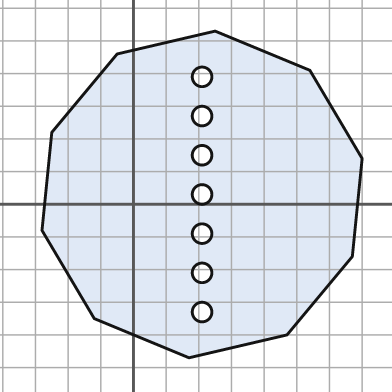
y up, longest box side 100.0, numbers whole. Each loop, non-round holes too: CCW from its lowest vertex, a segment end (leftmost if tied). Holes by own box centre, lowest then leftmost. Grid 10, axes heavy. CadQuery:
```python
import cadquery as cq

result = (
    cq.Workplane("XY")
    .moveTo(17.0, -47.0)
    .lineTo(47.0, -40.0)
    .lineTo(67.0, -16.0)
    .lineTo(70.0, 14.0)
    .lineTo(54.0, 41.0)
    .lineTo(25.0, 53.0)
    .lineTo(-5.0, 46.0)
    .lineTo(-25.0, 22.0)
    .lineTo(-28.0, -8.0)
    .lineTo(-12.0, -35.0)
    .close()
    .moveTo(21.0, -33.0)
    .circle(3.0)
    .moveTo(21.0, -21.0)
    .circle(3.0)
    .moveTo(21.0, -9.0)
    .circle(3.0)
    .moveTo(21.0, 3.0)
    .circle(3.0)
    .moveTo(21.0, 15.0)
    .circle(3.0)
    .moveTo(21.0, 27.0)
    .circle(3.0)
    .moveTo(21.0, 39.0)
    .circle(3.0)
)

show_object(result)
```